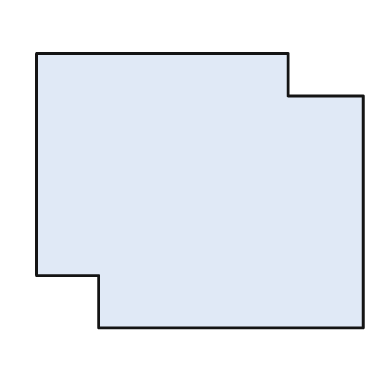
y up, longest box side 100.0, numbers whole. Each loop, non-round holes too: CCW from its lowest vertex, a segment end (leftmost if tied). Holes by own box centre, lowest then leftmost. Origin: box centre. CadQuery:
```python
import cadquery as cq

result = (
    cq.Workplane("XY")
    .moveTo(-31.0, -42.0)
    .lineTo(50.0, -42.0)
    .lineTo(50.0, 29.0)
    .lineTo(27.0, 29.0)
    .lineTo(27.0, 42.0)
    .lineTo(-50.0, 42.0)
    .lineTo(-50.0, -26.0)
    .lineTo(-31.0, -26.0)
    .close()
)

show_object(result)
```